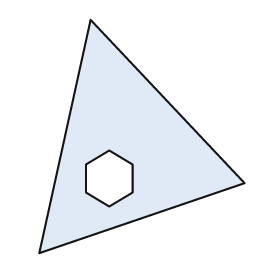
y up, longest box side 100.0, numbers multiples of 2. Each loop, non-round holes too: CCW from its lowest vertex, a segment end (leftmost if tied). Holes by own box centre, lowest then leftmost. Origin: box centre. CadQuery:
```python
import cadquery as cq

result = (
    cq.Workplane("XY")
    .moveTo(-44.0, -50.0)
    .lineTo(44.0, -20.0)
    .lineTo(-22.0, 50.0)
    .close()
    .moveTo(-14.0, -30.0)
    .lineTo(-4.0, -24.0)
    .lineTo(-4.0, -12.0)
    .lineTo(-14.0, -6.0)
    .lineTo(-24.0, -12.0)
    .lineTo(-24.0, -24.0)
    .close()
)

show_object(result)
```